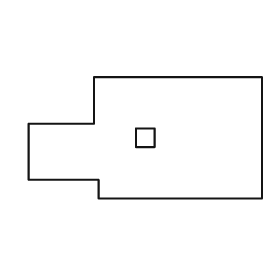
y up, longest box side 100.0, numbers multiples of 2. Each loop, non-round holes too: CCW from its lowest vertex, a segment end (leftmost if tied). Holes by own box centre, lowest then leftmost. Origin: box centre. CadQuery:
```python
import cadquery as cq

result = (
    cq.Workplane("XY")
    .moveTo(-20.0, -26.0)
    .lineTo(50.0, -26.0)
    .lineTo(50.0, 26.0)
    .lineTo(-22.0, 26.0)
    .lineTo(-22.0, 6.0)
    .lineTo(-50.0, 6.0)
    .lineTo(-50.0, -18.0)
    .lineTo(-20.0, -18.0)
    .close()
    .moveTo(-4.0, -4.0)
    .lineTo(4.0, -4.0)
    .lineTo(4.0, 4.0)
    .lineTo(-4.0, 4.0)
    .close()
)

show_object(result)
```